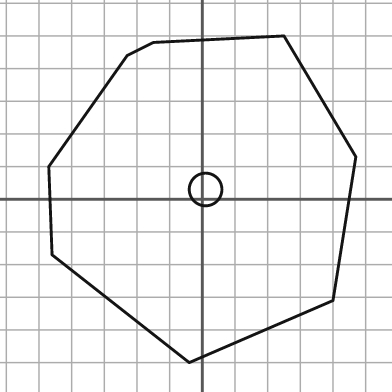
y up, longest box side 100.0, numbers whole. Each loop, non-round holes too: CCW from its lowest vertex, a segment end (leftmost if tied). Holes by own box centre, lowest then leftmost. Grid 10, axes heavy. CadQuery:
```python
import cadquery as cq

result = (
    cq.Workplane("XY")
    .moveTo(-4.0, -50.0)
    .lineTo(40.0, -31.0)
    .lineTo(47.0, 13.0)
    .lineTo(25.0, 50.0)
    .lineTo(-15.0, 48.0)
    .lineTo(-23.0, 44.0)
    .lineTo(-47.0, 10.0)
    .lineTo(-46.0, -17.0)
    .close()
    .moveTo(1.0, 3.0)
    .circle(5.0)
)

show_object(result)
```